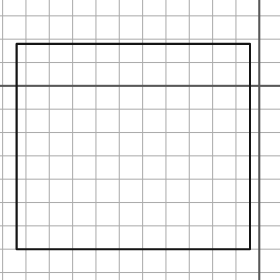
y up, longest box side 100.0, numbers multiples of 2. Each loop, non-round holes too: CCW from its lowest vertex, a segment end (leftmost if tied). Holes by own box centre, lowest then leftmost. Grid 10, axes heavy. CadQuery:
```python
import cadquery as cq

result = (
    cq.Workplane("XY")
    .moveTo(-104.0, -70.0)
    .lineTo(-4.0, -70.0)
    .lineTo(-4.0, 18.0)
    .lineTo(-104.0, 18.0)
    .close()
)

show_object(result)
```